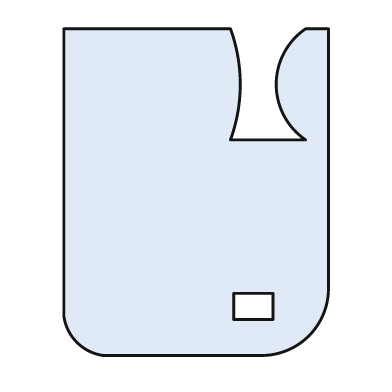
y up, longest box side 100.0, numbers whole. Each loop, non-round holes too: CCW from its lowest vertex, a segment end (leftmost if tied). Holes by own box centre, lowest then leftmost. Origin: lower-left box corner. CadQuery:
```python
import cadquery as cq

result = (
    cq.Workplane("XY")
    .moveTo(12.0, 0.0)
    .lineTo(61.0, 0.0)
    .threePointArc((75.0, 6.0), (81.0, 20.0))
    .lineTo(81.0, 100.0)
    .lineTo(74.0, 100.0)
    .threePointArc((65.0, 83.0), (74.0, 66.0))
    .lineTo(51.0, 66.0)
    .threePointArc((54.0, 83.0), (51.0, 100.0))
    .lineTo(0.0, 100.0)
    .lineTo(0.0, 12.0)
    .threePointArc((4.0, 4.0), (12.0, 0.0))
    .close()
    .moveTo(52.0, 11.0)
    .lineTo(64.0, 11.0)
    .lineTo(64.0, 19.0)
    .lineTo(52.0, 19.0)
    .close()
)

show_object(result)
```